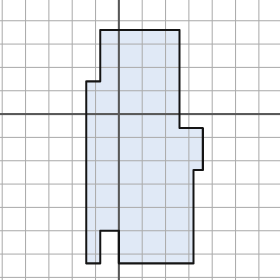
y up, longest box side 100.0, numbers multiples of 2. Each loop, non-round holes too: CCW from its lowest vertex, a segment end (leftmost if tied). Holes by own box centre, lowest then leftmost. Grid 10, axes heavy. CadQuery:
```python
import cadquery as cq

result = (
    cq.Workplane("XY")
    .moveTo(-14.0, -64.0)
    .lineTo(-8.0, -64.0)
    .lineTo(-8.0, -50.0)
    .lineTo(0.0, -50.0)
    .lineTo(0.0, -64.0)
    .lineTo(32.0, -64.0)
    .lineTo(32.0, -24.0)
    .lineTo(36.0, -24.0)
    .lineTo(36.0, -6.0)
    .lineTo(26.0, -6.0)
    .lineTo(26.0, 36.0)
    .lineTo(-8.0, 36.0)
    .lineTo(-8.0, 14.0)
    .lineTo(-14.0, 14.0)
    .close()
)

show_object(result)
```